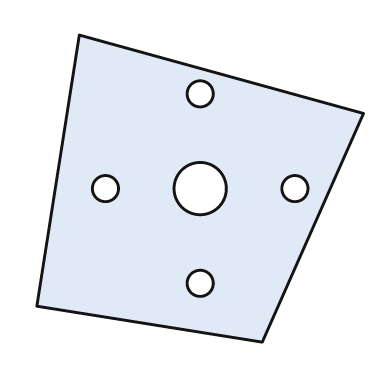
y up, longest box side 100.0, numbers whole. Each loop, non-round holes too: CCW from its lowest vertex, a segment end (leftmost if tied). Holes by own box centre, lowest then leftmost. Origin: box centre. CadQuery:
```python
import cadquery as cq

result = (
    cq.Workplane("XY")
    .moveTo(19.0, -47.0)
    .lineTo(50.0, 23.0)
    .lineTo(-37.0, 47.0)
    .lineTo(-50.0, -36.0)
    .close()
    .moveTo(0.0, -29.0)
    .circle(4.0)
    .moveTo(-29.0, 0.0)
    .circle(4.0)
    .moveTo(0.0, 0.0)
    .circle(8.0)
    .moveTo(29.0, 0.0)
    .circle(4.0)
    .moveTo(0.0, 29.0)
    .circle(4.0)
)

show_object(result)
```